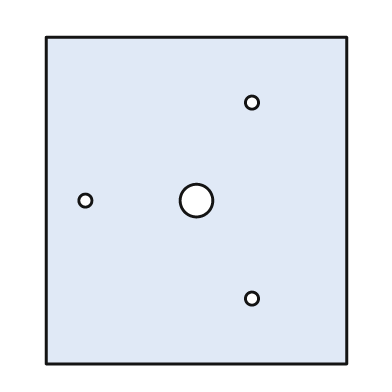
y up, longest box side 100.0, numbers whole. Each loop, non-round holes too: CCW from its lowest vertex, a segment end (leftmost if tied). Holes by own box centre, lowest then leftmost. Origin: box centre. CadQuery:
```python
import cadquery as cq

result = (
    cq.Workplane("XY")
    .moveTo(-46.0, -50.0)
    .lineTo(46.0, -50.0)
    .lineTo(46.0, 50.0)
    .lineTo(-46.0, 50.0)
    .close()
    .moveTo(17.0, -30.0)
    .circle(2.0)
    .moveTo(-34.0, 0.0)
    .circle(2.0)
    .moveTo(0.0, 0.0)
    .circle(5.0)
    .moveTo(17.0, 30.0)
    .circle(2.0)
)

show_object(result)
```